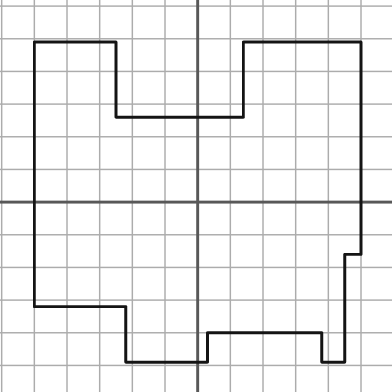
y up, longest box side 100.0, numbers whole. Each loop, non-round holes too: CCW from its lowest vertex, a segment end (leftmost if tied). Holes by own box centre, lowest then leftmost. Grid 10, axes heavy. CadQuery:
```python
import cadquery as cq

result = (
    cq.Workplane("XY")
    .moveTo(-22.0, -49.0)
    .lineTo(3.0, -49.0)
    .lineTo(3.0, -40.0)
    .lineTo(38.0, -40.0)
    .lineTo(38.0, -49.0)
    .lineTo(45.0, -49.0)
    .lineTo(45.0, -16.0)
    .lineTo(50.0, -16.0)
    .lineTo(50.0, 49.0)
    .lineTo(14.0, 49.0)
    .lineTo(14.0, 26.0)
    .lineTo(-25.0, 26.0)
    .lineTo(-25.0, 49.0)
    .lineTo(-50.0, 49.0)
    .lineTo(-50.0, -32.0)
    .lineTo(-22.0, -32.0)
    .close()
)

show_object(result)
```